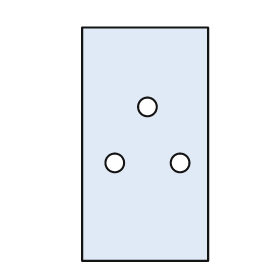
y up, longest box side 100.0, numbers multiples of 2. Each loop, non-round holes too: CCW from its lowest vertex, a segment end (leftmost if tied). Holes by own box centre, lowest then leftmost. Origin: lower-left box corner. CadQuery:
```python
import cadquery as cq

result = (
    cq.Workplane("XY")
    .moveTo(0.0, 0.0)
    .lineTo(54.0, 0.0)
    .lineTo(54.0, 100.0)
    .lineTo(0.0, 100.0)
    .close()
    .moveTo(14.0, 42.0)
    .circle(4.0)
    .moveTo(42.0, 42.0)
    .circle(4.0)
    .moveTo(28.0, 66.0)
    .circle(4.0)
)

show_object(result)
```